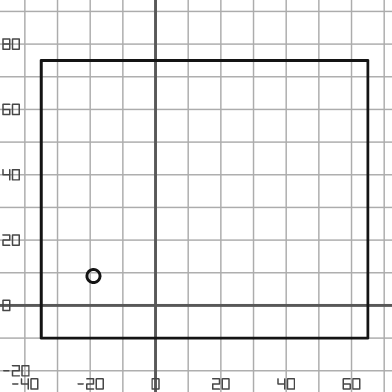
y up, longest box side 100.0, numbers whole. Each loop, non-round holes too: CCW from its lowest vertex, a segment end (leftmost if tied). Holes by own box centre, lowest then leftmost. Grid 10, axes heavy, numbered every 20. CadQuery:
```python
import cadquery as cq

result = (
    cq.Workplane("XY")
    .moveTo(-35.0, -10.0)
    .lineTo(65.0, -10.0)
    .lineTo(65.0, 75.0)
    .lineTo(-35.0, 75.0)
    .close()
    .moveTo(-19.0, 9.0)
    .circle(2.0)
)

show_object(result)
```